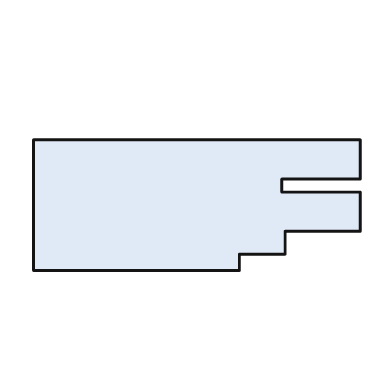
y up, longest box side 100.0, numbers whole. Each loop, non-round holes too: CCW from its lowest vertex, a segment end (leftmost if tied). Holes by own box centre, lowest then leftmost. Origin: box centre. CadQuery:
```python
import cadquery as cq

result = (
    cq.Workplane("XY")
    .moveTo(-50.0, -20.0)
    .lineTo(13.0, -20.0)
    .lineTo(13.0, -15.0)
    .lineTo(27.0, -15.0)
    .lineTo(27.0, -8.0)
    .lineTo(50.0, -8.0)
    .lineTo(50.0, 4.0)
    .lineTo(26.0, 4.0)
    .lineTo(26.0, 8.0)
    .lineTo(50.0, 8.0)
    .lineTo(50.0, 20.0)
    .lineTo(-50.0, 20.0)
    .close()
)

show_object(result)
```